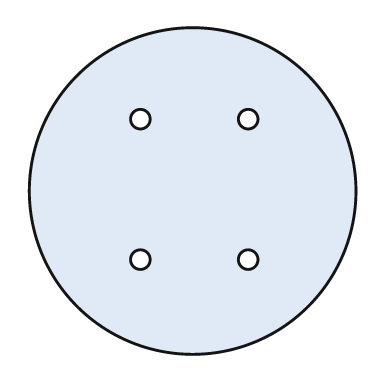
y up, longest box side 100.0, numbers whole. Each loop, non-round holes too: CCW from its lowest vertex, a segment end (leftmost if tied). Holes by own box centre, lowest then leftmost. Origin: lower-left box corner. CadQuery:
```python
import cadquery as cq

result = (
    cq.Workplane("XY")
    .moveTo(50.0, 50.0)
    .circle(50.0)
    .moveTo(34.0, 29.0)
    .circle(3.0)
    .moveTo(67.0, 29.0)
    .circle(3.0)
    .moveTo(34.0, 72.0)
    .circle(3.0)
    .moveTo(67.0, 72.0)
    .circle(3.0)
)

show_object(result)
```